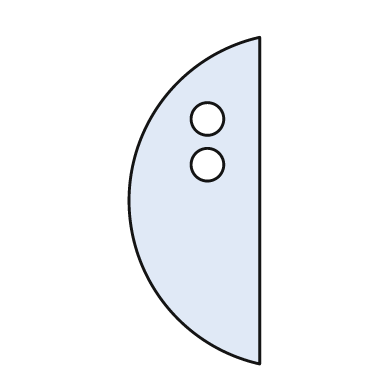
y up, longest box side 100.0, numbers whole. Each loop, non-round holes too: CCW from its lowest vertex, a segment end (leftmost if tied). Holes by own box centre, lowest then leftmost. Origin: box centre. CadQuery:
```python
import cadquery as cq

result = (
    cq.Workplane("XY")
    .moveTo(20.0, -50.0)
    .lineTo(20.0, 50.0)
    .threePointArc((-20.0, 0.0), (20.0, -50.0))
    .close()
    .moveTo(4.0, 11.0)
    .circle(5.0)
    .moveTo(4.0, 25.0)
    .circle(5.0)
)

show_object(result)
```